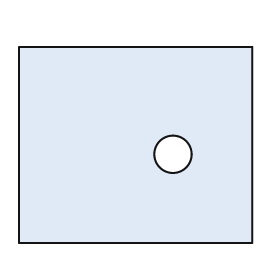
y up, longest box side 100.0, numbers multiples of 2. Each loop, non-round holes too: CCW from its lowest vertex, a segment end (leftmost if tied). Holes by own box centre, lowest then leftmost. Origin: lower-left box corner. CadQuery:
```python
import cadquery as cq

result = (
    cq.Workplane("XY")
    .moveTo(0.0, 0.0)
    .lineTo(100.0, 0.0)
    .lineTo(100.0, 84.0)
    .lineTo(0.0, 84.0)
    .close()
    .moveTo(66.0, 38.0)
    .circle(8.0)
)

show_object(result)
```